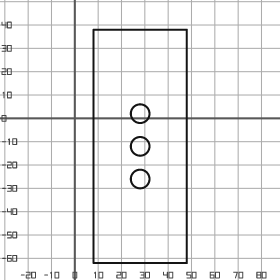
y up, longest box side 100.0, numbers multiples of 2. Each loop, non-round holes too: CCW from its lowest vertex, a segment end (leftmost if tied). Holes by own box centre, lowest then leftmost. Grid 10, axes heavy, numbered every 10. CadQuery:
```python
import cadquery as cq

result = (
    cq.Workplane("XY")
    .moveTo(8.0, -62.0)
    .lineTo(48.0, -62.0)
    .lineTo(48.0, 38.0)
    .lineTo(8.0, 38.0)
    .close()
    .moveTo(28.0, -26.0)
    .circle(4.0)
    .moveTo(28.0, -12.0)
    .circle(4.0)
    .moveTo(28.0, 2.0)
    .circle(4.0)
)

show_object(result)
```